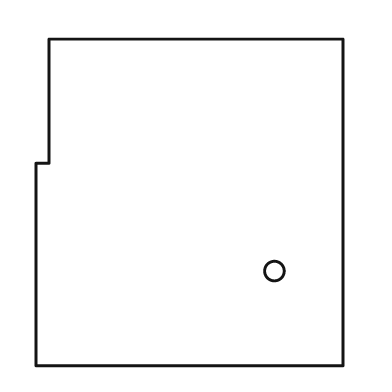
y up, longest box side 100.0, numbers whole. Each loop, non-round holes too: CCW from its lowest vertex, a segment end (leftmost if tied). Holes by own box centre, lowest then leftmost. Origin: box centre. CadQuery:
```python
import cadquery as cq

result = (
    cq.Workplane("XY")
    .moveTo(-47.0, -50.0)
    .lineTo(47.0, -50.0)
    .lineTo(47.0, 50.0)
    .lineTo(-43.0, 50.0)
    .lineTo(-43.0, 12.0)
    .lineTo(-47.0, 12.0)
    .close()
    .moveTo(26.0, -21.0)
    .circle(3.0)
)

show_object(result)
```